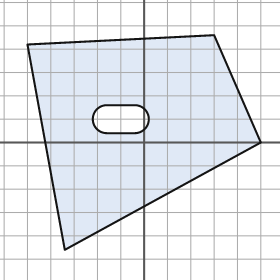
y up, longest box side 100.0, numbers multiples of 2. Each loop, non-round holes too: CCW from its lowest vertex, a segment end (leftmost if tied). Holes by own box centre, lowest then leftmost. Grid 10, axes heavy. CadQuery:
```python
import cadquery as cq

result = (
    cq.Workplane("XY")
    .moveTo(-34.0, -46.0)
    .lineTo(50.0, 0.0)
    .lineTo(30.0, 46.0)
    .lineTo(-50.0, 42.0)
    .close()
    .moveTo(-16.0, 4.0)
    .lineTo(-4.0, 4.0)
    .threePointArc((2.0, 10.0), (-4.0, 16.0))
    .lineTo(-16.0, 16.0)
    .threePointArc((-22.0, 10.0), (-16.0, 4.0))
    .close()
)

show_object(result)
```